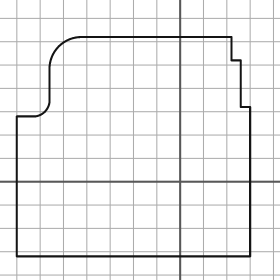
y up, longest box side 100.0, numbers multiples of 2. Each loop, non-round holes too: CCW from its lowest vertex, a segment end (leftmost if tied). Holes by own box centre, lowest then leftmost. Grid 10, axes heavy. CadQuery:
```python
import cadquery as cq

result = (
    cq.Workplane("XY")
    .moveTo(-70.0, -32.0)
    .lineTo(30.0, -32.0)
    .lineTo(30.0, 32.0)
    .lineTo(26.0, 32.0)
    .lineTo(26.0, 52.0)
    .lineTo(22.0, 52.0)
    .lineTo(22.0, 62.0)
    .lineTo(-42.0, 62.0)
    .threePointArc((-52.0, 58.0), (-56.0, 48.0))
    .lineTo(-56.0, 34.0)
    .threePointArc((-58.0, 30.0), (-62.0, 28.0))
    .lineTo(-70.0, 28.0)
    .close()
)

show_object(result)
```